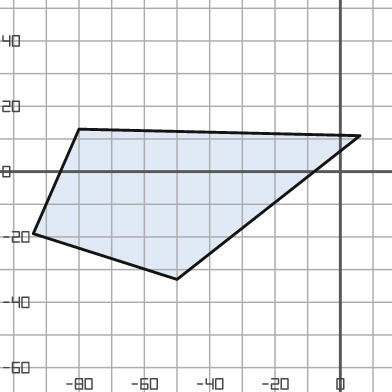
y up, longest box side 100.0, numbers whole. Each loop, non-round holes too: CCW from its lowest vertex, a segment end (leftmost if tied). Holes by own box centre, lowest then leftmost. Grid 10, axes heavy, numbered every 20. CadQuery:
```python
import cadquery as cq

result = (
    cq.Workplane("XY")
    .moveTo(-50.0, -33.0)
    .lineTo(6.0, 11.0)
    .lineTo(-80.0, 13.0)
    .lineTo(-94.0, -19.0)
    .close()
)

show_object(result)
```